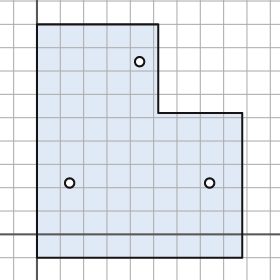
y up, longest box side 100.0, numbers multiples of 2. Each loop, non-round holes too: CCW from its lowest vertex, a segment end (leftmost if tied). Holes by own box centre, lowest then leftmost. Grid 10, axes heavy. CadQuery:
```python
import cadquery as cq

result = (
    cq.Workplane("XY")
    .moveTo(0.0, -10.0)
    .lineTo(88.0, -10.0)
    .lineTo(88.0, 52.0)
    .lineTo(52.0, 52.0)
    .lineTo(52.0, 90.0)
    .lineTo(0.0, 90.0)
    .close()
    .moveTo(14.0, 22.0)
    .circle(2.0)
    .moveTo(74.0, 22.0)
    .circle(2.0)
    .moveTo(44.0, 74.0)
    .circle(2.0)
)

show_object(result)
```